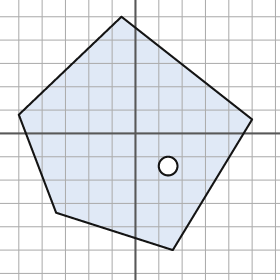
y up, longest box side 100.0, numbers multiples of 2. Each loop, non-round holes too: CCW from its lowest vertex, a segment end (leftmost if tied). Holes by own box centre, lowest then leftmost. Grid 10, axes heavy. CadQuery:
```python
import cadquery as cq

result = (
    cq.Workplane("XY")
    .moveTo(16.0, -50.0)
    .lineTo(50.0, 6.0)
    .lineTo(-6.0, 50.0)
    .lineTo(-50.0, 8.0)
    .lineTo(-34.0, -34.0)
    .close()
    .moveTo(14.0, -14.0)
    .circle(4.0)
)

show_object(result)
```